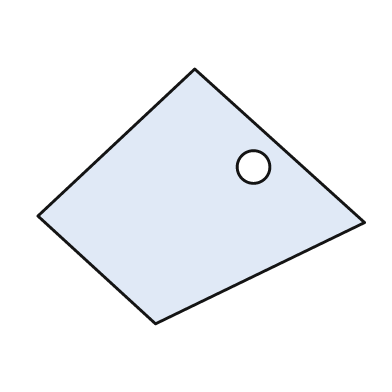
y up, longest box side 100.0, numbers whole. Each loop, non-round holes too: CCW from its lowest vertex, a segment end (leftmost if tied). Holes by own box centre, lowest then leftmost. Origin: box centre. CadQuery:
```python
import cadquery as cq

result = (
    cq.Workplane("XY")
    .moveTo(-14.0, -39.0)
    .lineTo(50.0, -8.0)
    .lineTo(-2.0, 39.0)
    .lineTo(-50.0, -6.0)
    .close()
    .moveTo(16.0, 9.0)
    .circle(5.0)
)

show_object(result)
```